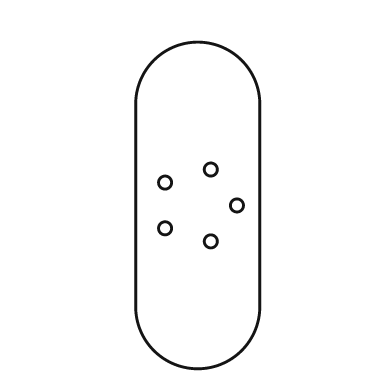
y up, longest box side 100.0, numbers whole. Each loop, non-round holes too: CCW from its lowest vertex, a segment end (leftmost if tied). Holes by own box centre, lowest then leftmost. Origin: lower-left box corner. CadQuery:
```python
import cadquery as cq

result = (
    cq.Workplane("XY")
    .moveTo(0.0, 19.0)
    .threePointArc((19.0, 0.0), (38.0, 19.0))
    .lineTo(38.0, 81.0)
    .threePointArc((19.0, 100.0), (0.0, 81.0))
    .close()
    .moveTo(23.0, 39.0)
    .circle(2.0)
    .moveTo(9.0, 43.0)
    .circle(2.0)
    .moveTo(31.0, 50.0)
    .circle(2.0)
    .moveTo(9.0, 57.0)
    .circle(2.0)
    .moveTo(23.0, 61.0)
    .circle(2.0)
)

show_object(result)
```